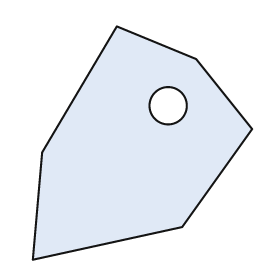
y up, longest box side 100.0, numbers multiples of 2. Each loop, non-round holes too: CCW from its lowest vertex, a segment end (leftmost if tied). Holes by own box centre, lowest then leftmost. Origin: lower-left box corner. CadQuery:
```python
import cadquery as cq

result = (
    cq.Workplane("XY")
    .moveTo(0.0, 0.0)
    .lineTo(64.0, 14.0)
    .lineTo(94.0, 56.0)
    .lineTo(70.0, 86.0)
    .lineTo(36.0, 100.0)
    .lineTo(4.0, 46.0)
    .close()
    .moveTo(58.0, 66.0)
    .circle(8.0)
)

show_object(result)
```